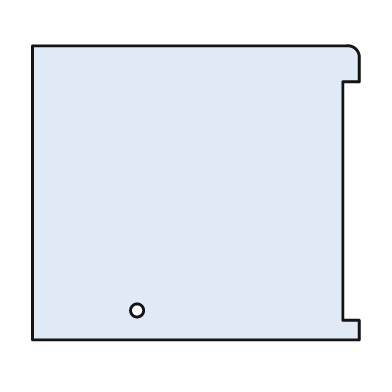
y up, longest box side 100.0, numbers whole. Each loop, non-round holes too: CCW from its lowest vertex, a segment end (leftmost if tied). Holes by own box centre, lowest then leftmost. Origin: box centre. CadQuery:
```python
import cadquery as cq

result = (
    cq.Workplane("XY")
    .moveTo(-50.0, -45.0)
    .lineTo(50.0, -45.0)
    .lineTo(50.0, -39.0)
    .lineTo(45.0, -39.0)
    .lineTo(45.0, 34.0)
    .lineTo(50.0, 34.0)
    .lineTo(50.0, 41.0)
    .threePointArc((49.0, 44.0), (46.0, 45.0))
    .lineTo(-50.0, 45.0)
    .close()
    .moveTo(-18.0, -36.0)
    .circle(2.0)
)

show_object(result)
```